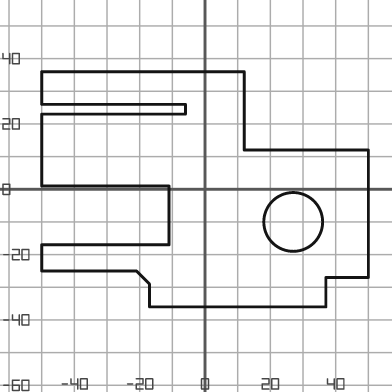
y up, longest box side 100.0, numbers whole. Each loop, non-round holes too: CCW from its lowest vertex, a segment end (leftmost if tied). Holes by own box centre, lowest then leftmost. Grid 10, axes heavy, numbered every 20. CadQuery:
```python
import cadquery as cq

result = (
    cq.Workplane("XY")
    .moveTo(-17.0, -36.0)
    .lineTo(37.0, -36.0)
    .lineTo(37.0, -27.0)
    .lineTo(50.0, -27.0)
    .lineTo(50.0, 12.0)
    .lineTo(12.0, 12.0)
    .lineTo(12.0, 36.0)
    .lineTo(-50.0, 36.0)
    .lineTo(-50.0, 26.0)
    .lineTo(-6.0, 26.0)
    .lineTo(-6.0, 23.0)
    .lineTo(-50.0, 23.0)
    .lineTo(-50.0, 1.0)
    .lineTo(-11.0, 1.0)
    .lineTo(-11.0, -17.0)
    .lineTo(-50.0, -17.0)
    .lineTo(-50.0, -25.0)
    .lineTo(-21.0, -25.0)
    .lineTo(-17.0, -29.0)
    .close()
    .moveTo(27.0, -10.0)
    .circle(9.0)
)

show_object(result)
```